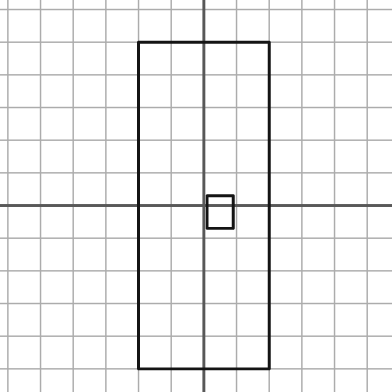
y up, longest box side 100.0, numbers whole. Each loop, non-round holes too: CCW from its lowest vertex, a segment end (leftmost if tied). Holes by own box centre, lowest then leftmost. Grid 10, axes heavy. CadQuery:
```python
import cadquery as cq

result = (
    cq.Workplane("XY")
    .moveTo(-20.0, -50.0)
    .lineTo(20.0, -50.0)
    .lineTo(20.0, 50.0)
    .lineTo(-20.0, 50.0)
    .close()
    .moveTo(1.0, -7.0)
    .lineTo(9.0, -7.0)
    .lineTo(9.0, 3.0)
    .lineTo(1.0, 3.0)
    .close()
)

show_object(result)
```